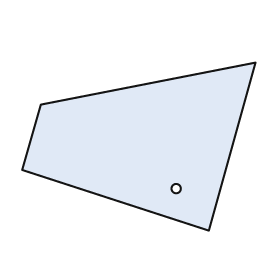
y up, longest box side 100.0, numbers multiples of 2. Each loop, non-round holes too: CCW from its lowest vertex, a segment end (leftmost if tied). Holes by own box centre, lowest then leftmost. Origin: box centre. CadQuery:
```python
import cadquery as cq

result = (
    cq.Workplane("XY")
    .moveTo(30.0, -36.0)
    .lineTo(50.0, 36.0)
    .lineTo(-42.0, 18.0)
    .lineTo(-50.0, -10.0)
    .close()
    .moveTo(16.0, -18.0)
    .circle(2.0)
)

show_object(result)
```